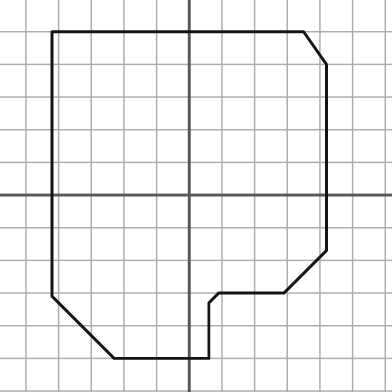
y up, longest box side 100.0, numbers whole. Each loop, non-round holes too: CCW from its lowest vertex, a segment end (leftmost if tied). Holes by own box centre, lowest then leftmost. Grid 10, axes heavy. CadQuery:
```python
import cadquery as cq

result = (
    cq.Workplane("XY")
    .moveTo(-23.0, -50.0)
    .lineTo(6.0, -50.0)
    .lineTo(6.0, -33.0)
    .lineTo(9.0, -30.0)
    .lineTo(29.0, -30.0)
    .lineTo(42.0, -17.0)
    .lineTo(42.0, 40.0)
    .lineTo(35.0, 50.0)
    .lineTo(-42.0, 50.0)
    .lineTo(-42.0, -31.0)
    .close()
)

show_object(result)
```